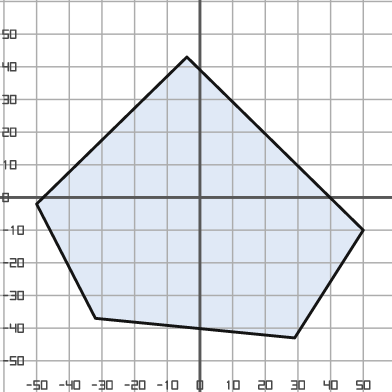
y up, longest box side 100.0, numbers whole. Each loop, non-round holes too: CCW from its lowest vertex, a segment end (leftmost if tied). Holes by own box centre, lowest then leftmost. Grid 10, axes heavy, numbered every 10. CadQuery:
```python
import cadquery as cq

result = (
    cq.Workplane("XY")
    .moveTo(29.0, -43.0)
    .lineTo(50.0, -10.0)
    .lineTo(-4.0, 43.0)
    .lineTo(-50.0, -2.0)
    .lineTo(-32.0, -37.0)
    .close()
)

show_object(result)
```